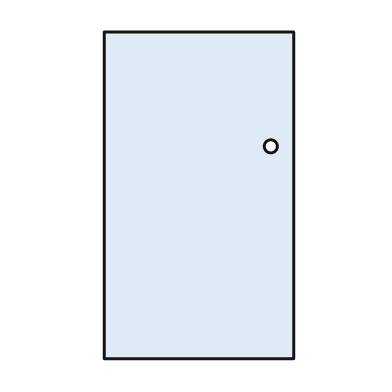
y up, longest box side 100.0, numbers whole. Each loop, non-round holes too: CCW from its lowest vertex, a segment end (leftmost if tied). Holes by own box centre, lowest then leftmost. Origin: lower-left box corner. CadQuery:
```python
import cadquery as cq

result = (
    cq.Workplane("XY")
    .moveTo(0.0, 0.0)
    .lineTo(58.0, 0.0)
    .lineTo(58.0, 100.0)
    .lineTo(0.0, 100.0)
    .close()
    .moveTo(51.0, 65.0)
    .circle(2.0)
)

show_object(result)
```